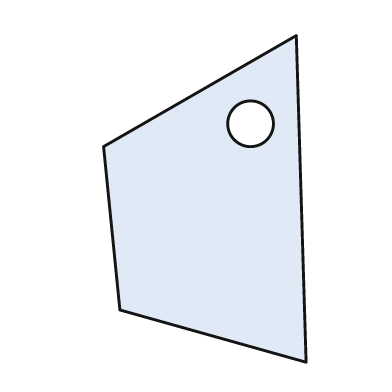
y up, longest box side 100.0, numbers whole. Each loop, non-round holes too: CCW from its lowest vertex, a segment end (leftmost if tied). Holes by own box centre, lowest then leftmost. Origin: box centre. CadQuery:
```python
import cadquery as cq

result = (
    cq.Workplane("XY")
    .moveTo(31.0, -50.0)
    .lineTo(28.0, 50.0)
    .lineTo(-31.0, 16.0)
    .lineTo(-26.0, -34.0)
    .close()
    .moveTo(14.0, 23.0)
    .circle(7.0)
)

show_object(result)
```